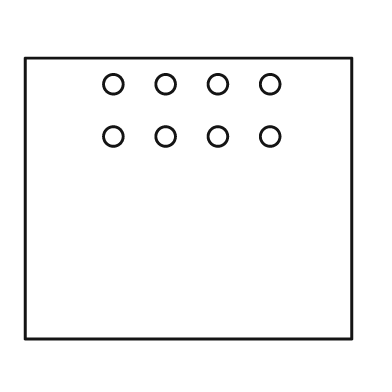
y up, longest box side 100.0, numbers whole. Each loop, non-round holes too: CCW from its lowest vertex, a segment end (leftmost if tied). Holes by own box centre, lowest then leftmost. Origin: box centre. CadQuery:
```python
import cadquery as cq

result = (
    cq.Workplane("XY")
    .moveTo(-50.0, -43.0)
    .lineTo(50.0, -43.0)
    .lineTo(50.0, 43.0)
    .lineTo(-50.0, 43.0)
    .close()
    .moveTo(-23.0, 19.0)
    .circle(3.0)
    .moveTo(-7.0, 19.0)
    .circle(3.0)
    .moveTo(9.0, 19.0)
    .circle(3.0)
    .moveTo(25.0, 19.0)
    .circle(3.0)
    .moveTo(-23.0, 35.0)
    .circle(3.0)
    .moveTo(-7.0, 35.0)
    .circle(3.0)
    .moveTo(9.0, 35.0)
    .circle(3.0)
    .moveTo(25.0, 35.0)
    .circle(3.0)
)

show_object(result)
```